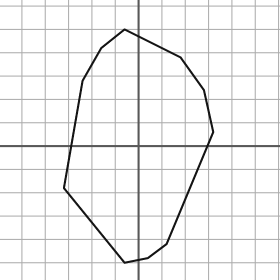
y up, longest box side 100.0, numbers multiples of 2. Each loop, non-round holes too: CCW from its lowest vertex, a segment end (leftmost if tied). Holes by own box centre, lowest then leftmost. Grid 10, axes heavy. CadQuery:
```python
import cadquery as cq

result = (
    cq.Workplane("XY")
    .moveTo(-6.0, -50.0)
    .lineTo(4.0, -48.0)
    .lineTo(12.0, -42.0)
    .lineTo(32.0, 6.0)
    .lineTo(28.0, 24.0)
    .lineTo(18.0, 38.0)
    .lineTo(-6.0, 50.0)
    .lineTo(-16.0, 42.0)
    .lineTo(-24.0, 28.0)
    .lineTo(-32.0, -18.0)
    .close()
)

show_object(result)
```